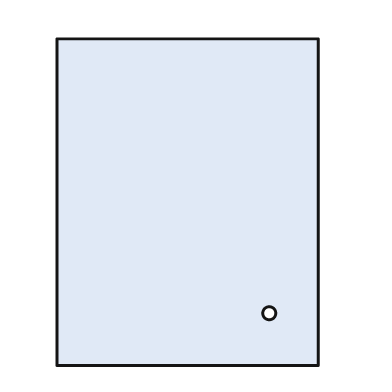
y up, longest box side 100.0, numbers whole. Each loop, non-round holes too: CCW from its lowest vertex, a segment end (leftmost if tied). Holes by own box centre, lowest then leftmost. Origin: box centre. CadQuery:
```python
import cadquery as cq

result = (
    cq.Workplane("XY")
    .moveTo(-40.0, -50.0)
    .lineTo(40.0, -50.0)
    .lineTo(40.0, 50.0)
    .lineTo(-40.0, 50.0)
    .close()
    .moveTo(25.0, -34.0)
    .circle(2.0)
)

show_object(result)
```